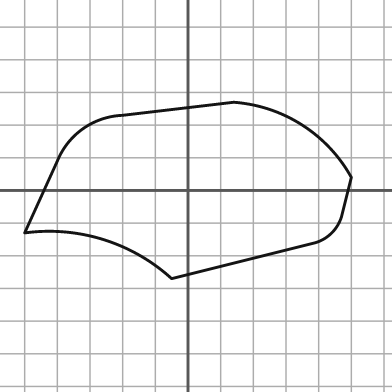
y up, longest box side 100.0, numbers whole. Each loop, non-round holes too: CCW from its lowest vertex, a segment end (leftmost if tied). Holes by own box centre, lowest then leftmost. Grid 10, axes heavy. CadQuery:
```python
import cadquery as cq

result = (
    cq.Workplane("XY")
    .moveTo(-5.0, -27.0)
    .lineTo(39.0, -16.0)
    .threePointArc((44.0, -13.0), (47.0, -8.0))
    .lineTo(50.0, 4.0)
    .threePointArc((35.0, 20.0), (14.0, 27.0))
    .lineTo(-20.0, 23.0)
    .threePointArc((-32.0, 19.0), (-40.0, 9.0))
    .lineTo(-50.0, -13.0)
    .threePointArc((-26.0, -15.0), (-5.0, -27.0))
    .close()
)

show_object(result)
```